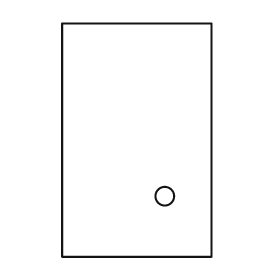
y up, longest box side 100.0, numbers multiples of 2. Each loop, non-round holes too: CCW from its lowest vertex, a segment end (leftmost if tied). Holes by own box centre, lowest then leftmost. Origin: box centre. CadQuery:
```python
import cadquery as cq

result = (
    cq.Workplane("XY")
    .moveTo(-32.0, -50.0)
    .lineTo(32.0, -50.0)
    .lineTo(32.0, 50.0)
    .lineTo(-32.0, 50.0)
    .close()
    .moveTo(12.0, -24.0)
    .circle(4.0)
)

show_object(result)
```